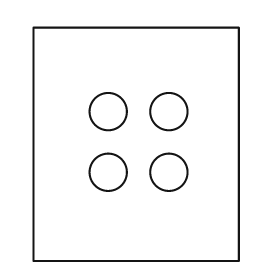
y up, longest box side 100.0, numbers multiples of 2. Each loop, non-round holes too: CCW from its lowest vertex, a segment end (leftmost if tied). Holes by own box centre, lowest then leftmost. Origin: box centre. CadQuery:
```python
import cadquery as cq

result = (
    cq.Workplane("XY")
    .moveTo(-44.0, -50.0)
    .lineTo(44.0, -50.0)
    .lineTo(44.0, 50.0)
    .lineTo(-44.0, 50.0)
    .close()
    .moveTo(-12.0, -12.0)
    .circle(8.0)
    .moveTo(14.0, -12.0)
    .circle(8.0)
    .moveTo(-12.0, 14.0)
    .circle(8.0)
    .moveTo(14.0, 14.0)
    .circle(8.0)
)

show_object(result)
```